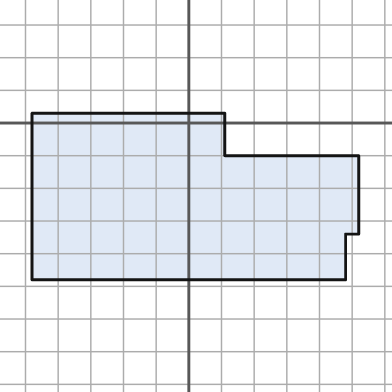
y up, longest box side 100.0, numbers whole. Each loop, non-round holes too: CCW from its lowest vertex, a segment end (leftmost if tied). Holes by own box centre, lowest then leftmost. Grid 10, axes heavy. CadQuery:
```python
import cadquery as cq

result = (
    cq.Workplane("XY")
    .moveTo(-48.0, -48.0)
    .lineTo(48.0, -48.0)
    .lineTo(48.0, -34.0)
    .lineTo(52.0, -34.0)
    .lineTo(52.0, -10.0)
    .lineTo(11.0, -10.0)
    .lineTo(11.0, 3.0)
    .lineTo(-48.0, 3.0)
    .close()
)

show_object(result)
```